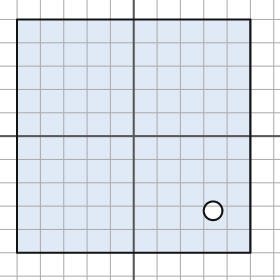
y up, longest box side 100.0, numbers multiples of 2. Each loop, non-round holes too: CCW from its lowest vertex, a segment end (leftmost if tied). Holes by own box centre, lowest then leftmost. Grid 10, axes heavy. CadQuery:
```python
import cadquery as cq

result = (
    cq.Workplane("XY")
    .moveTo(-50.0, -50.0)
    .lineTo(50.0, -50.0)
    .lineTo(50.0, 50.0)
    .lineTo(-50.0, 50.0)
    .close()
    .moveTo(34.0, -32.0)
    .circle(4.0)
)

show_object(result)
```